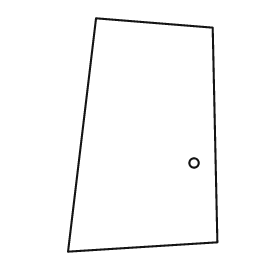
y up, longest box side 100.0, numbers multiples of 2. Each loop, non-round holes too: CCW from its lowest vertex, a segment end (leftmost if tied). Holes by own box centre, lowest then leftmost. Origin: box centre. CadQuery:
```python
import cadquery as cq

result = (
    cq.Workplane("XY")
    .moveTo(-32.0, -50.0)
    .lineTo(32.0, -46.0)
    .lineTo(30.0, 46.0)
    .lineTo(-20.0, 50.0)
    .close()
    .moveTo(22.0, -12.0)
    .circle(2.0)
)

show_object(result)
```